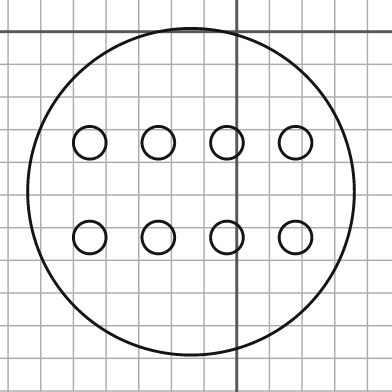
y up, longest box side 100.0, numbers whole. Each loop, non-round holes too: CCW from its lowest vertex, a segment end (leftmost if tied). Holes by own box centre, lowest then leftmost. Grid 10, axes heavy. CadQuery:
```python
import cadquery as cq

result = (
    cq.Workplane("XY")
    .moveTo(-14.0, -49.0)
    .circle(50.0)
    .moveTo(-45.0, -63.0)
    .circle(5.0)
    .moveTo(-24.0, -63.0)
    .circle(5.0)
    .moveTo(-3.0, -63.0)
    .circle(5.0)
    .moveTo(18.0, -63.0)
    .circle(5.0)
    .moveTo(-45.0, -34.0)
    .circle(5.0)
    .moveTo(-24.0, -34.0)
    .circle(5.0)
    .moveTo(-3.0, -34.0)
    .circle(5.0)
    .moveTo(18.0, -34.0)
    .circle(5.0)
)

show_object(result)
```